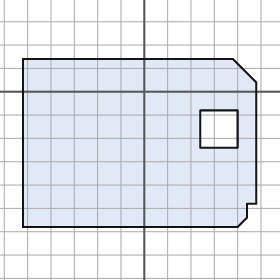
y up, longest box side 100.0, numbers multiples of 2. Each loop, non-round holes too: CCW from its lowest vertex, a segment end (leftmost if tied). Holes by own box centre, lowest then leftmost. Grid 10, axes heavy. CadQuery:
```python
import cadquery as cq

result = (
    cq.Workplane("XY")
    .moveTo(-52.0, -58.0)
    .lineTo(40.0, -58.0)
    .lineTo(44.0, -54.0)
    .lineTo(44.0, -48.0)
    .lineTo(48.0, -48.0)
    .lineTo(48.0, 4.0)
    .lineTo(38.0, 14.0)
    .lineTo(-52.0, 14.0)
    .close()
    .moveTo(24.0, -24.0)
    .lineTo(40.0, -24.0)
    .lineTo(40.0, -8.0)
    .lineTo(24.0, -8.0)
    .close()
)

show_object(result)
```